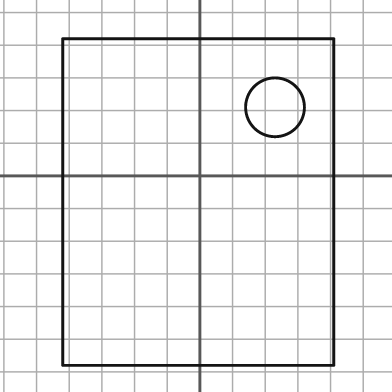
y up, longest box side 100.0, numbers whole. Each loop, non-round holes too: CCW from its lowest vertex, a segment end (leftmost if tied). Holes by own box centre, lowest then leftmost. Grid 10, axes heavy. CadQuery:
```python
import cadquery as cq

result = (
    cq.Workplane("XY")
    .moveTo(-42.0, -58.0)
    .lineTo(41.0, -58.0)
    .lineTo(41.0, 42.0)
    .lineTo(-42.0, 42.0)
    .close()
    .moveTo(23.0, 21.0)
    .circle(9.0)
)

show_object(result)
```